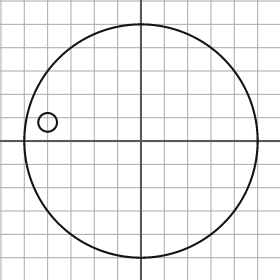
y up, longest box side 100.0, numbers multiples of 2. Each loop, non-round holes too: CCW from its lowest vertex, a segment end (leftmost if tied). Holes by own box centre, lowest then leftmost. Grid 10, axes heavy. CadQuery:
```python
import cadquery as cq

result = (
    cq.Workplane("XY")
    .moveTo(0.0, 0.0)
    .circle(50.0)
    .moveTo(-40.0, 8.0)
    .circle(4.0)
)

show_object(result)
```